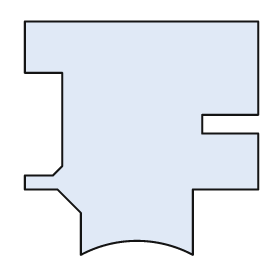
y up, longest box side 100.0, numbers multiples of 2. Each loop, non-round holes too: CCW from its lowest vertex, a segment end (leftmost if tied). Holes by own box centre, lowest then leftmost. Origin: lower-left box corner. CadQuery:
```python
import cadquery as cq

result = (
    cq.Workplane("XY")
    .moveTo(24.0, 0.0)
    .threePointArc((48.0, 6.0), (72.0, 0.0))
    .lineTo(72.0, 28.0)
    .lineTo(100.0, 28.0)
    .lineTo(100.0, 52.0)
    .lineTo(76.0, 52.0)
    .lineTo(76.0, 60.0)
    .lineTo(100.0, 60.0)
    .lineTo(100.0, 100.0)
    .lineTo(0.0, 100.0)
    .lineTo(0.0, 78.0)
    .lineTo(16.0, 78.0)
    .lineTo(16.0, 38.0)
    .lineTo(12.0, 34.0)
    .lineTo(0.0, 34.0)
    .lineTo(0.0, 28.0)
    .lineTo(14.0, 28.0)
    .lineTo(24.0, 18.0)
    .close()
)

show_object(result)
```